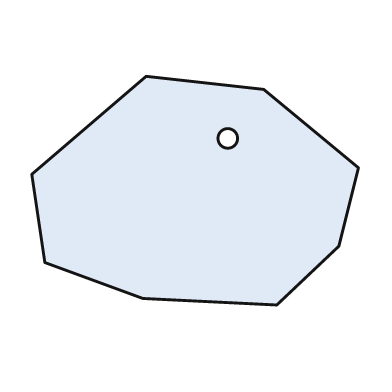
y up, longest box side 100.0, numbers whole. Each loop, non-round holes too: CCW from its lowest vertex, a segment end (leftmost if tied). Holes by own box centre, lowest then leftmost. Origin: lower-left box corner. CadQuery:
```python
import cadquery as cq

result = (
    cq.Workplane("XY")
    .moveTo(75.0, 0.0)
    .lineTo(94.0, 18.0)
    .lineTo(100.0, 42.0)
    .lineTo(71.0, 66.0)
    .lineTo(35.0, 70.0)
    .lineTo(0.0, 40.0)
    .lineTo(4.0, 13.0)
    .lineTo(34.0, 2.0)
    .close()
    .moveTo(60.0, 51.0)
    .circle(3.0)
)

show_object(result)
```